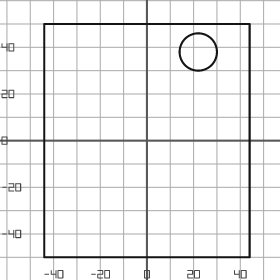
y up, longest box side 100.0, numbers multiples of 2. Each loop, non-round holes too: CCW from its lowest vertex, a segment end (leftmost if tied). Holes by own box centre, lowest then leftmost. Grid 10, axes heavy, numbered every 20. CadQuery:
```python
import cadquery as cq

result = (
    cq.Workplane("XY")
    .moveTo(-44.0, -50.0)
    .lineTo(44.0, -50.0)
    .lineTo(44.0, 50.0)
    .lineTo(-44.0, 50.0)
    .close()
    .moveTo(22.0, 38.0)
    .circle(8.0)
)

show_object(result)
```